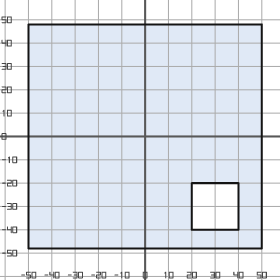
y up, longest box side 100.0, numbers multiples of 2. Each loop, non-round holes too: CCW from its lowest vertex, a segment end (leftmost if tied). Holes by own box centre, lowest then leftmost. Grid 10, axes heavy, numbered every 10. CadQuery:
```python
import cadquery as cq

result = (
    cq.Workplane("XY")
    .moveTo(-50.0, -48.0)
    .lineTo(50.0, -48.0)
    .lineTo(50.0, 48.0)
    .lineTo(-50.0, 48.0)
    .close()
    .moveTo(20.0, -40.0)
    .lineTo(40.0, -40.0)
    .lineTo(40.0, -20.0)
    .lineTo(20.0, -20.0)
    .close()
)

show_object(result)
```